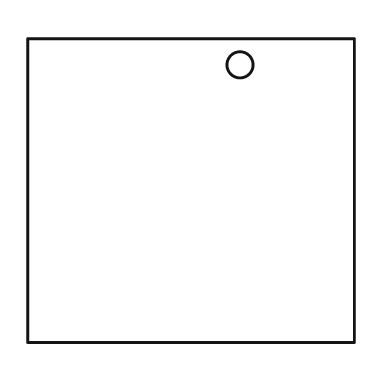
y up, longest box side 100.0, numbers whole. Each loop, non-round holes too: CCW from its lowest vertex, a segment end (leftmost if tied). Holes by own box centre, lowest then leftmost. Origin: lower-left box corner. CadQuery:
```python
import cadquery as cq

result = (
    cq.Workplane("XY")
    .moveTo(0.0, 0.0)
    .lineTo(100.0, 0.0)
    .lineTo(100.0, 93.0)
    .lineTo(0.0, 93.0)
    .close()
    .moveTo(65.0, 85.0)
    .circle(4.0)
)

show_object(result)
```